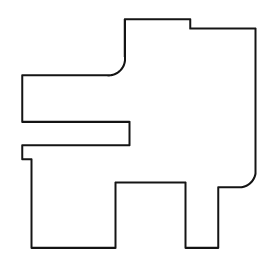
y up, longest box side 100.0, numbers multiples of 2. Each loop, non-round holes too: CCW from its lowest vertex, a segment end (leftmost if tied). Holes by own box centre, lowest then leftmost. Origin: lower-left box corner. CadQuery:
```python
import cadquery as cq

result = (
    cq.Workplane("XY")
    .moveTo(4.0, 0.0)
    .lineTo(40.0, 0.0)
    .lineTo(40.0, 28.0)
    .lineTo(70.0, 28.0)
    .lineTo(70.0, 0.0)
    .lineTo(84.0, 0.0)
    .lineTo(84.0, 26.0)
    .lineTo(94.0, 26.0)
    .threePointArc((98.0, 28.0), (100.0, 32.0))
    .lineTo(100.0, 94.0)
    .lineTo(72.0, 94.0)
    .lineTo(72.0, 98.0)
    .lineTo(44.0, 98.0)
    .lineTo(44.0, 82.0)
    .threePointArc((42.0, 76.0), (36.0, 74.0))
    .lineTo(0.0, 74.0)
    .lineTo(0.0, 54.0)
    .lineTo(46.0, 54.0)
    .lineTo(46.0, 44.0)
    .lineTo(0.0, 44.0)
    .lineTo(0.0, 38.0)
    .lineTo(4.0, 38.0)
    .close()
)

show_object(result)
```